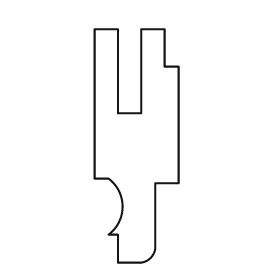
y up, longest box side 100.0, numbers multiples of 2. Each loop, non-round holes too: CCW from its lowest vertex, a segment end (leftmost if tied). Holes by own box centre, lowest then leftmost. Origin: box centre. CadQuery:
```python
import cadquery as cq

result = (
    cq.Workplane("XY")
    .moveTo(-8.0, -50.0)
    .lineTo(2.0, -50.0)
    .threePointArc((6.0, -48.0), (8.0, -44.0))
    .lineTo(8.0, -16.0)
    .lineTo(18.0, -16.0)
    .lineTo(18.0, 34.0)
    .lineTo(12.0, 34.0)
    .lineTo(12.0, 50.0)
    .lineTo(2.0, 50.0)
    .lineTo(2.0, 14.0)
    .lineTo(-8.0, 14.0)
    .lineTo(-8.0, 50.0)
    .lineTo(-18.0, 50.0)
    .lineTo(-18.0, -14.0)
    .lineTo(-12.0, -14.0)
    .threePointArc((-6.0, -26.0), (-12.0, -38.0))
    .lineTo(-8.0, -38.0)
    .close()
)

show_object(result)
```